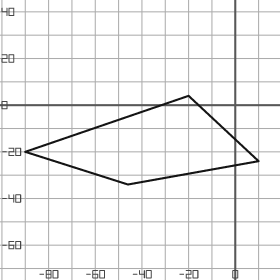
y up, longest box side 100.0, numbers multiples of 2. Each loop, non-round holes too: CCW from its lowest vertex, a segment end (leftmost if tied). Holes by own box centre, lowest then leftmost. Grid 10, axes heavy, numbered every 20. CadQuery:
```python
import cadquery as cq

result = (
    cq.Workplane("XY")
    .moveTo(-46.0, -34.0)
    .lineTo(10.0, -24.0)
    .lineTo(-20.0, 4.0)
    .lineTo(-90.0, -20.0)
    .close()
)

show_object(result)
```